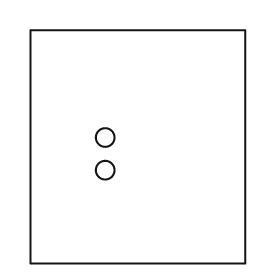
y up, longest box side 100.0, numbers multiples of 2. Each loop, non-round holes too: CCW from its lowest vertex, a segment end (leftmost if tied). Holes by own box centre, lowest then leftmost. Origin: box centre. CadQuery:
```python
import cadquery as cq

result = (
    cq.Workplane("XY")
    .moveTo(-46.0, -50.0)
    .lineTo(46.0, -50.0)
    .lineTo(46.0, 50.0)
    .lineTo(-46.0, 50.0)
    .close()
    .moveTo(-14.0, -10.0)
    .circle(4.0)
    .moveTo(-14.0, 4.0)
    .circle(4.0)
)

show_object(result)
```